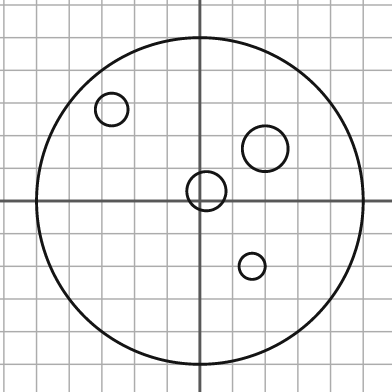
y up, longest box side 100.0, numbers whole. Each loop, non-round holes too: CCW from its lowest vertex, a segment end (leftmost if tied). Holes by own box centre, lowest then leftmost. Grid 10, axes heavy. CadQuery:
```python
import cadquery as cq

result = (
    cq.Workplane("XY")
    .moveTo(0.0, 0.0)
    .circle(50.0)
    .moveTo(16.0, -20.0)
    .circle(4.0)
    .moveTo(2.0, 3.0)
    .circle(6.0)
    .moveTo(20.0, 16.0)
    .circle(7.0)
    .moveTo(-27.0, 28.0)
    .circle(5.0)
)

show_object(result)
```